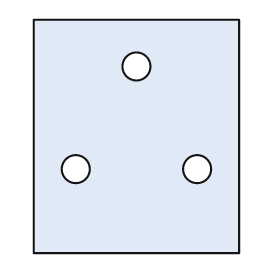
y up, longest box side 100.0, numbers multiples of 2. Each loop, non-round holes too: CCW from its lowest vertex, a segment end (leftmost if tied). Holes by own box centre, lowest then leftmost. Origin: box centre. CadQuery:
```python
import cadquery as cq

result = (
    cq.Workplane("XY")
    .moveTo(-44.0, -50.0)
    .lineTo(44.0, -50.0)
    .lineTo(44.0, 50.0)
    .lineTo(-44.0, 50.0)
    .close()
    .moveTo(-26.0, -14.0)
    .circle(6.0)
    .moveTo(26.0, -14.0)
    .circle(6.0)
    .moveTo(0.0, 30.0)
    .circle(6.0)
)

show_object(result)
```